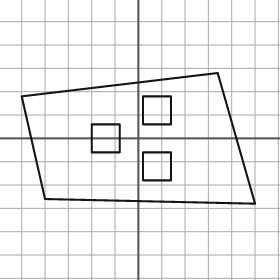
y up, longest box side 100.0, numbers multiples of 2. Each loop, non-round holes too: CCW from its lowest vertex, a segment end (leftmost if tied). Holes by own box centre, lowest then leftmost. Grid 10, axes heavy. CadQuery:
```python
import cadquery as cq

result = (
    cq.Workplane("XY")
    .moveTo(50.0, -28.0)
    .lineTo(34.0, 28.0)
    .lineTo(-50.0, 18.0)
    .lineTo(-40.0, -26.0)
    .close()
    .moveTo(2.0, -18.0)
    .lineTo(14.0, -18.0)
    .lineTo(14.0, -6.0)
    .lineTo(2.0, -6.0)
    .close()
    .moveTo(-20.0, -6.0)
    .lineTo(-8.0, -6.0)
    .lineTo(-8.0, 6.0)
    .lineTo(-20.0, 6.0)
    .close()
    .moveTo(2.0, 6.0)
    .lineTo(14.0, 6.0)
    .lineTo(14.0, 18.0)
    .lineTo(2.0, 18.0)
    .close()
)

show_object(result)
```